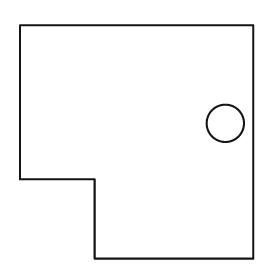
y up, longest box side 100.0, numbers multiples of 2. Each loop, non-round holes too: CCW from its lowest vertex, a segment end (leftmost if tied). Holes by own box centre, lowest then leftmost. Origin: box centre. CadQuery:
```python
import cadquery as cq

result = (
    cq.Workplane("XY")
    .moveTo(-18.0, -50.0)
    .lineTo(50.0, -50.0)
    .lineTo(50.0, 50.0)
    .lineTo(-50.0, 50.0)
    .lineTo(-50.0, -16.0)
    .lineTo(-18.0, -16.0)
    .close()
    .moveTo(38.0, 8.0)
    .circle(8.0)
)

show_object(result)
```